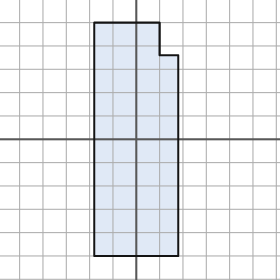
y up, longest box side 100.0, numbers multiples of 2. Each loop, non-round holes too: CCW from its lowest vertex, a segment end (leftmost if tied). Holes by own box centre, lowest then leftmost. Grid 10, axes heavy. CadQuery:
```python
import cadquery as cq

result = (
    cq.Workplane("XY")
    .moveTo(-18.0, -50.0)
    .lineTo(18.0, -50.0)
    .lineTo(18.0, 36.0)
    .lineTo(10.0, 36.0)
    .lineTo(10.0, 50.0)
    .lineTo(-18.0, 50.0)
    .close()
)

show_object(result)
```